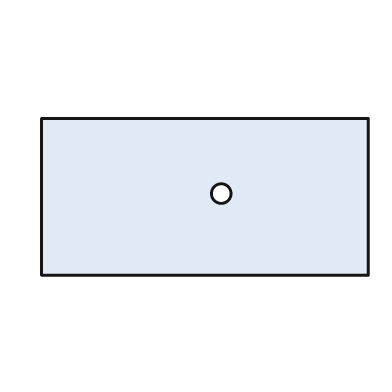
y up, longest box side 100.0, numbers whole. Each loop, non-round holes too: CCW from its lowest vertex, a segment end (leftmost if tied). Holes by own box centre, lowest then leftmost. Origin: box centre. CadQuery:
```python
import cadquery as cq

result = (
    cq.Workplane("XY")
    .moveTo(-50.0, -24.0)
    .lineTo(50.0, -24.0)
    .lineTo(50.0, 24.0)
    .lineTo(-50.0, 24.0)
    .close()
    .moveTo(5.0, 1.0)
    .circle(3.0)
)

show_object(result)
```